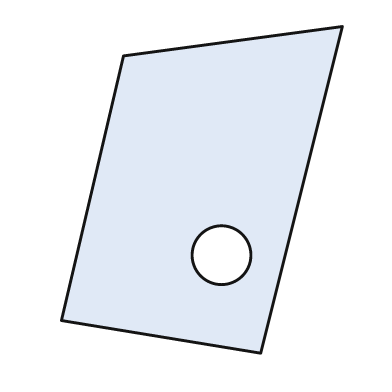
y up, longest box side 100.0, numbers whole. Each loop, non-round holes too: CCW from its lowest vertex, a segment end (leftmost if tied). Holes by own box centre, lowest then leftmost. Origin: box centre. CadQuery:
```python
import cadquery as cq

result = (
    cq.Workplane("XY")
    .moveTo(18.0, -50.0)
    .lineTo(43.0, 50.0)
    .lineTo(-24.0, 41.0)
    .lineTo(-43.0, -40.0)
    .close()
    .moveTo(6.0, -20.0)
    .circle(9.0)
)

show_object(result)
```